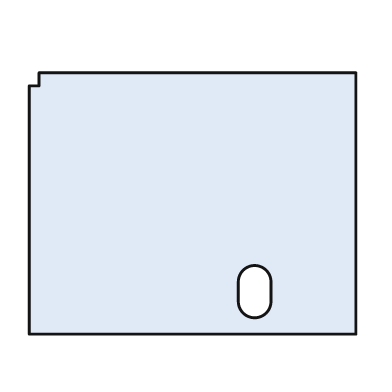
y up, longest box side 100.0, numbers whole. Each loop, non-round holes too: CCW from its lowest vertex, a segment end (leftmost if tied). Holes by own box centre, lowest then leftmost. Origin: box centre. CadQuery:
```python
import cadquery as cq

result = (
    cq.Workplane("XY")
    .moveTo(-50.0, -40.0)
    .lineTo(50.0, -40.0)
    .lineTo(50.0, 40.0)
    .lineTo(-47.0, 40.0)
    .lineTo(-47.0, 36.0)
    .lineTo(-50.0, 36.0)
    .close()
    .moveTo(14.0, -30.0)
    .threePointArc((19.0, -35.0), (24.0, -30.0))
    .lineTo(24.0, -24.0)
    .threePointArc((19.0, -19.0), (14.0, -24.0))
    .close()
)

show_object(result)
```